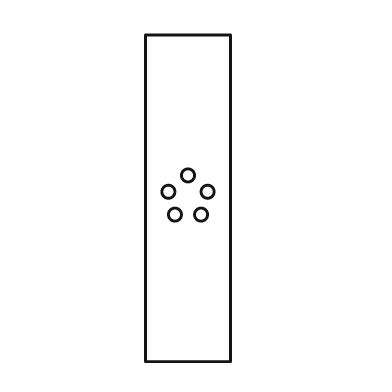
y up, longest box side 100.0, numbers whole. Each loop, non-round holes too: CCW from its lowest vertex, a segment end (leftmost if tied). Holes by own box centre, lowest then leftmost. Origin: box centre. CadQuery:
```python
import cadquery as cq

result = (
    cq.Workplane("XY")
    .moveTo(-13.0, -50.0)
    .lineTo(13.0, -50.0)
    .lineTo(13.0, 50.0)
    .lineTo(-13.0, 50.0)
    .close()
    .moveTo(-4.0, -5.0)
    .circle(2.0)
    .moveTo(4.0, -5.0)
    .circle(2.0)
    .moveTo(-6.0, 2.0)
    .circle(2.0)
    .moveTo(6.0, 2.0)
    .circle(2.0)
    .moveTo(0.0, 7.0)
    .circle(2.0)
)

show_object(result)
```